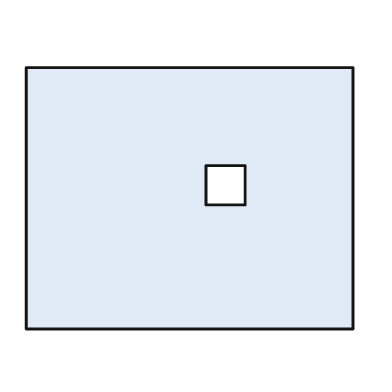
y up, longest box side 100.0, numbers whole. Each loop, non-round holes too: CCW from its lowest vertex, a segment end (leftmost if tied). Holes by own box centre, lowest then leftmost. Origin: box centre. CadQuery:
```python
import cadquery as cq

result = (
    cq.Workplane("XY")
    .moveTo(-50.0, -40.0)
    .lineTo(50.0, -40.0)
    .lineTo(50.0, 40.0)
    .lineTo(-50.0, 40.0)
    .close()
    .moveTo(5.0, -2.0)
    .lineTo(17.0, -2.0)
    .lineTo(17.0, 10.0)
    .lineTo(5.0, 10.0)
    .close()
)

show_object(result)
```